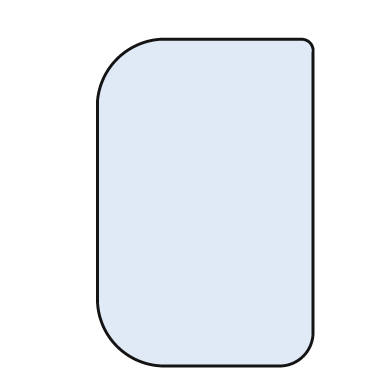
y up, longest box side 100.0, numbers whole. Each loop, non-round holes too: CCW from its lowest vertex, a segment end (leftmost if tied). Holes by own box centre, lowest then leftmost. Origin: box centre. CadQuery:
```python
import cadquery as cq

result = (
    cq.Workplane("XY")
    .moveTo(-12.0, -50.0)
    .lineTo(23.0, -50.0)
    .threePointArc((30.0, -47.0), (33.0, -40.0))
    .lineTo(33.0, 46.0)
    .threePointArc((32.0, 49.0), (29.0, 50.0))
    .lineTo(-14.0, 50.0)
    .threePointArc((-27.0, 44.0), (-33.0, 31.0))
    .lineTo(-33.0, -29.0)
    .threePointArc((-27.0, -44.0), (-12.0, -50.0))
    .close()
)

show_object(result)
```